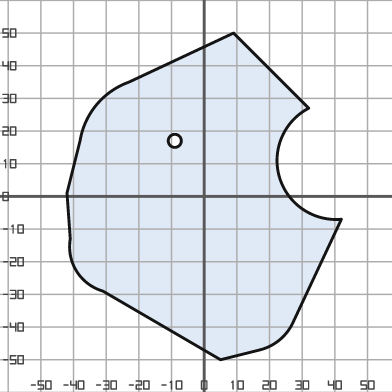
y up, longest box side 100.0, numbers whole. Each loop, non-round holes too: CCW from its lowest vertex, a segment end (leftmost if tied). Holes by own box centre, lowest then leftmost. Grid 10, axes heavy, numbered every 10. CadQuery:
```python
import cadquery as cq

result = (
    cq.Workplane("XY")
    .moveTo(5.0, -50.0)
    .lineTo(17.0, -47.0)
    .threePointArc((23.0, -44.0), (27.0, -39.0))
    .lineTo(42.0, -7.0)
    .threePointArc((23.0, 6.0), (32.0, 27.0))
    .lineTo(9.0, 50.0)
    .lineTo(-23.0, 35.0)
    .threePointArc((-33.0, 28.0), (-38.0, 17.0))
    .lineTo(-42.0, 1.0)
    .lineTo(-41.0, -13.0)
    .threePointArc((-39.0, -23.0), (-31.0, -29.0))
    .close()
    .moveTo(-9.0, 17.0)
    .circle(2.0)
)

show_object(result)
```